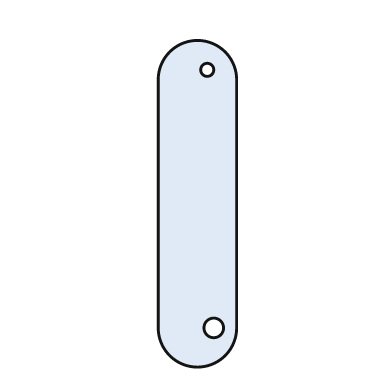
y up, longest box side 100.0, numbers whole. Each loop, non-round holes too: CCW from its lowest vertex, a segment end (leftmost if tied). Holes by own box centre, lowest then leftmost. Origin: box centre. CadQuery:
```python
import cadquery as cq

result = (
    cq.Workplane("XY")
    .moveTo(-12.0, -38.0)
    .threePointArc((0.0, -50.0), (12.0, -38.0))
    .lineTo(12.0, 38.0)
    .threePointArc((0.0, 50.0), (-12.0, 38.0))
    .close()
    .moveTo(5.0, -38.0)
    .circle(3.0)
    .moveTo(3.0, 41.0)
    .circle(2.0)
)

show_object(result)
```